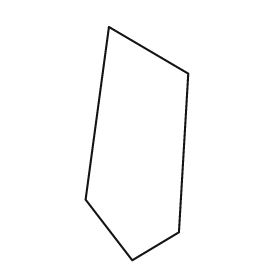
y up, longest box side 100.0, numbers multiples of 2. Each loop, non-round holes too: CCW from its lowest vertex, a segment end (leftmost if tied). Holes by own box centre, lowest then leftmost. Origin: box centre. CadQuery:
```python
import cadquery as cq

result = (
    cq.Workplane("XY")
    .moveTo(-2.0, -50.0)
    .lineTo(18.0, -38.0)
    .lineTo(22.0, 30.0)
    .lineTo(-12.0, 50.0)
    .lineTo(-22.0, -24.0)
    .close()
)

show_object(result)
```